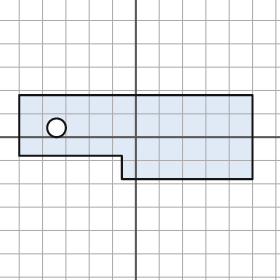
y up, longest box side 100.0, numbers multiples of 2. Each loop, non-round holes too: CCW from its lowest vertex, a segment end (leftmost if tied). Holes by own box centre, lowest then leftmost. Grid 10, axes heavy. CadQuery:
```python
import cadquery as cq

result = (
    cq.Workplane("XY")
    .moveTo(-6.0, -18.0)
    .lineTo(50.0, -18.0)
    .lineTo(50.0, 18.0)
    .lineTo(-50.0, 18.0)
    .lineTo(-50.0, -8.0)
    .lineTo(-6.0, -8.0)
    .close()
    .moveTo(-34.0, 4.0)
    .circle(4.0)
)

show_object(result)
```